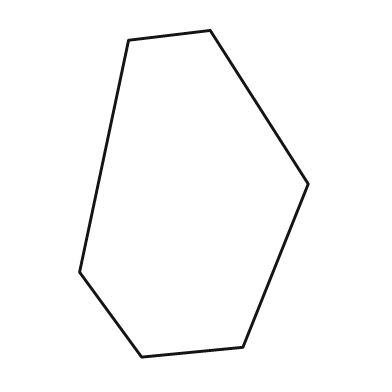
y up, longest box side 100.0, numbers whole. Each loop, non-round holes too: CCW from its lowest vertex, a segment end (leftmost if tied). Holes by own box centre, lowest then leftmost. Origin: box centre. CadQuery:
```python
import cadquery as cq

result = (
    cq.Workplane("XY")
    .moveTo(-16.0, -50.0)
    .lineTo(15.0, -47.0)
    .lineTo(35.0, 3.0)
    .lineTo(5.0, 50.0)
    .lineTo(-20.0, 47.0)
    .lineTo(-35.0, -24.0)
    .close()
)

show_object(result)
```